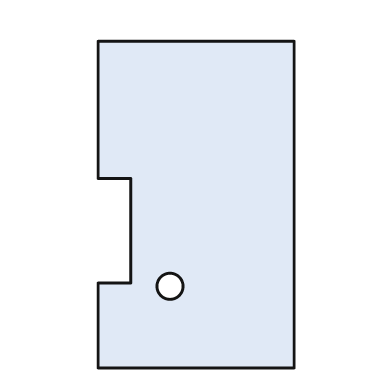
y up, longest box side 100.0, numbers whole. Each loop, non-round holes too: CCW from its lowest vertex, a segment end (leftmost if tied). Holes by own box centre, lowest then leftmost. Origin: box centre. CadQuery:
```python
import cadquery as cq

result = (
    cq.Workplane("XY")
    .moveTo(-30.0, -50.0)
    .lineTo(30.0, -50.0)
    .lineTo(30.0, 50.0)
    .lineTo(-30.0, 50.0)
    .lineTo(-30.0, 8.0)
    .lineTo(-20.0, 8.0)
    .lineTo(-20.0, -24.0)
    .lineTo(-30.0, -24.0)
    .close()
    .moveTo(-8.0, -25.0)
    .circle(4.0)
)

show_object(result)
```